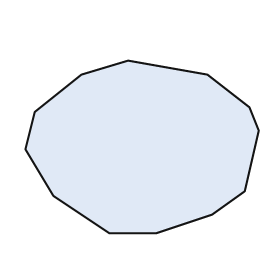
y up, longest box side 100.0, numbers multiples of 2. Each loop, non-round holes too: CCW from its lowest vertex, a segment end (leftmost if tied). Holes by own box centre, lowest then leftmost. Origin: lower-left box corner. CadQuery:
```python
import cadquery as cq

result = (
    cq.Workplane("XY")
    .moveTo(36.0, 0.0)
    .lineTo(56.0, 0.0)
    .lineTo(80.0, 8.0)
    .lineTo(94.0, 18.0)
    .lineTo(100.0, 44.0)
    .lineTo(96.0, 54.0)
    .lineTo(78.0, 68.0)
    .lineTo(44.0, 74.0)
    .lineTo(24.0, 68.0)
    .lineTo(4.0, 52.0)
    .lineTo(0.0, 36.0)
    .lineTo(12.0, 16.0)
    .close()
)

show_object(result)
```